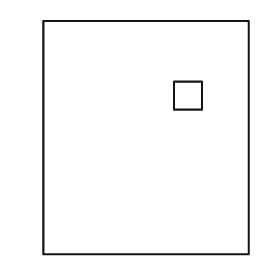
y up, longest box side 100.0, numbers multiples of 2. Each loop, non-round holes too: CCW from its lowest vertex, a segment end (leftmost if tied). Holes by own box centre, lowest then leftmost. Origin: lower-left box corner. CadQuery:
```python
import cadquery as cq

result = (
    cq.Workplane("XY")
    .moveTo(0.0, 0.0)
    .lineTo(88.0, 0.0)
    .lineTo(88.0, 100.0)
    .lineTo(0.0, 100.0)
    .close()
    .moveTo(56.0, 62.0)
    .lineTo(68.0, 62.0)
    .lineTo(68.0, 74.0)
    .lineTo(56.0, 74.0)
    .close()
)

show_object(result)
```